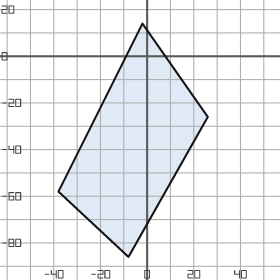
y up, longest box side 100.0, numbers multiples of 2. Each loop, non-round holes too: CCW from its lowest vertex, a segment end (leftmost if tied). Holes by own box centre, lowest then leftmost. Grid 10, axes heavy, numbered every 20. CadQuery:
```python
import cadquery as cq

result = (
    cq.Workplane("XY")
    .moveTo(-8.0, -86.0)
    .lineTo(26.0, -26.0)
    .lineTo(-2.0, 14.0)
    .lineTo(-38.0, -58.0)
    .close()
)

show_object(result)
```